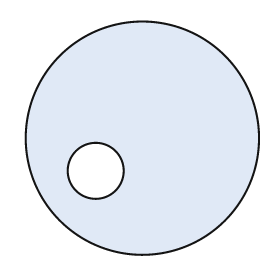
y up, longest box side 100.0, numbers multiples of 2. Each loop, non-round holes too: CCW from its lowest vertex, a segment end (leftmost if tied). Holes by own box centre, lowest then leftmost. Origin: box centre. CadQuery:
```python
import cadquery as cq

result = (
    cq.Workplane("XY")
    .moveTo(0.0, 0.0)
    .circle(50.0)
    .moveTo(-20.0, -14.0)
    .circle(12.0)
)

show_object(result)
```